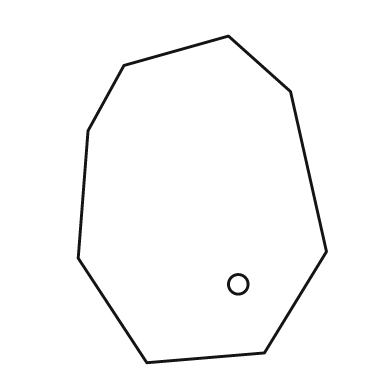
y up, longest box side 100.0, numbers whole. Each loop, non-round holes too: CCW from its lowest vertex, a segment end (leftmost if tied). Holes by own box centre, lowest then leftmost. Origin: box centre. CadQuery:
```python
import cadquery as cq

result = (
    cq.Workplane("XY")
    .moveTo(-17.0, -50.0)
    .lineTo(19.0, -47.0)
    .lineTo(38.0, -16.0)
    .lineTo(27.0, 33.0)
    .lineTo(8.0, 50.0)
    .lineTo(-24.0, 41.0)
    .lineTo(-35.0, 21.0)
    .lineTo(-38.0, -18.0)
    .close()
    .moveTo(11.0, -26.0)
    .circle(3.0)
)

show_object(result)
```